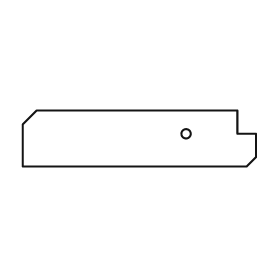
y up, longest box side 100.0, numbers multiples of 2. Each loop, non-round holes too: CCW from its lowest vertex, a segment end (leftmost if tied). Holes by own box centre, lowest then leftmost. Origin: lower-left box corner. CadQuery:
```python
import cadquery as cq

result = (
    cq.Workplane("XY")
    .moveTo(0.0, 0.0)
    .lineTo(96.0, 0.0)
    .lineTo(100.0, 4.0)
    .lineTo(100.0, 14.0)
    .lineTo(92.0, 14.0)
    .lineTo(92.0, 24.0)
    .lineTo(6.0, 24.0)
    .lineTo(0.0, 18.0)
    .close()
    .moveTo(70.0, 14.0)
    .circle(2.0)
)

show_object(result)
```